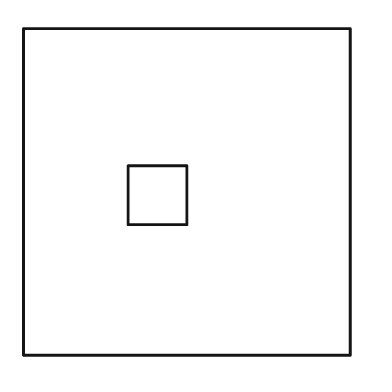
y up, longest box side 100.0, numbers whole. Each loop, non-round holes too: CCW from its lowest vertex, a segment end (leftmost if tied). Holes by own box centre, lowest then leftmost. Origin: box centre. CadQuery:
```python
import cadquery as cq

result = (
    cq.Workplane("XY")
    .moveTo(-50.0, -50.0)
    .lineTo(50.0, -50.0)
    .lineTo(50.0, 50.0)
    .lineTo(-50.0, 50.0)
    .close()
    .moveTo(-18.0, -10.0)
    .lineTo(0.0, -10.0)
    .lineTo(0.0, 8.0)
    .lineTo(-18.0, 8.0)
    .close()
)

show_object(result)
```